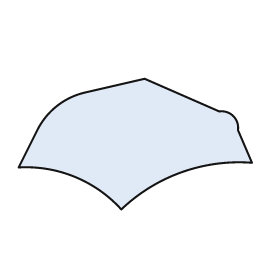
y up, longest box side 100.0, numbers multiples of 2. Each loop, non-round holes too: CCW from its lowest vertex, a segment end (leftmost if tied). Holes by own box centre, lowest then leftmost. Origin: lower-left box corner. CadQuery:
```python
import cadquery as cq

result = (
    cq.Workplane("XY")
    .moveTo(44.0, 0.0)
    .threePointArc((70.0, 16.0), (100.0, 20.0))
    .lineTo(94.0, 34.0)
    .threePointArc((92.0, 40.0), (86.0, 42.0))
    .lineTo(54.0, 56.0)
    .lineTo(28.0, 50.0)
    .threePointArc((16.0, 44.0), (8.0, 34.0))
    .lineTo(0.0, 18.0)
    .threePointArc((24.0, 14.0), (44.0, 0.0))
    .close()
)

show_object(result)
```